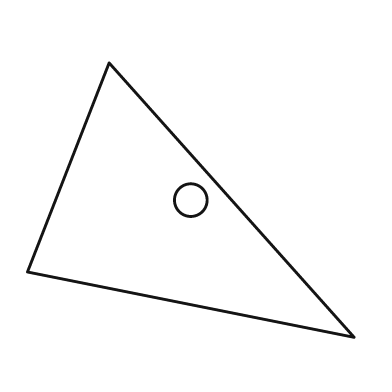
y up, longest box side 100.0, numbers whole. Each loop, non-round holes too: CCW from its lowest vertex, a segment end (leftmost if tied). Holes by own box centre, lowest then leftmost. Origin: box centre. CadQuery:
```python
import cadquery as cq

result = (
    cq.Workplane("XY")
    .moveTo(50.0, -42.0)
    .lineTo(-25.0, 42.0)
    .lineTo(-50.0, -22.0)
    .close()
    .moveTo(0.0, 0.0)
    .circle(5.0)
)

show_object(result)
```